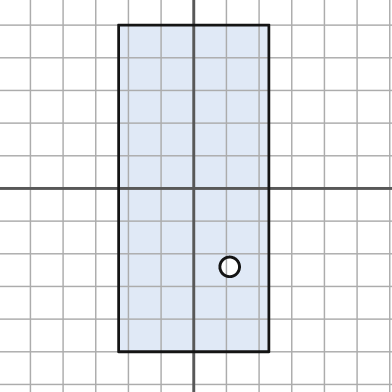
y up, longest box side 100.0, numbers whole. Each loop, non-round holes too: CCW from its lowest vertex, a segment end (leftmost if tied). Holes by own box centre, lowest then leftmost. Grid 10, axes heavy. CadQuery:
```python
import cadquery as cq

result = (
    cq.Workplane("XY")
    .moveTo(-23.0, -50.0)
    .lineTo(23.0, -50.0)
    .lineTo(23.0, 50.0)
    .lineTo(-23.0, 50.0)
    .close()
    .moveTo(11.0, -24.0)
    .circle(3.0)
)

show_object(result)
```